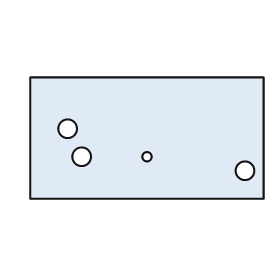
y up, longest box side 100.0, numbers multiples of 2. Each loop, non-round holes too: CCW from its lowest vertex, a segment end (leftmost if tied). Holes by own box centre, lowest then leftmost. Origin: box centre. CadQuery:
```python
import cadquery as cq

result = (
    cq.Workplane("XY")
    .moveTo(-50.0, -26.0)
    .lineTo(50.0, -26.0)
    .lineTo(50.0, 26.0)
    .lineTo(-50.0, 26.0)
    .close()
    .moveTo(42.0, -14.0)
    .circle(4.0)
    .moveTo(-28.0, -8.0)
    .circle(4.0)
    .moveTo(0.0, -8.0)
    .circle(2.0)
    .moveTo(-34.0, 4.0)
    .circle(4.0)
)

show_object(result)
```